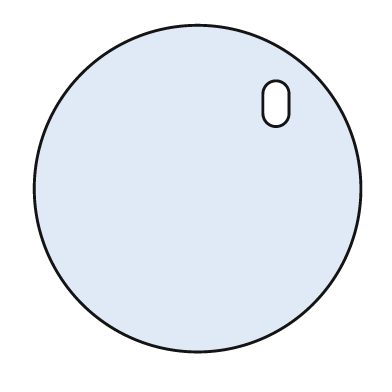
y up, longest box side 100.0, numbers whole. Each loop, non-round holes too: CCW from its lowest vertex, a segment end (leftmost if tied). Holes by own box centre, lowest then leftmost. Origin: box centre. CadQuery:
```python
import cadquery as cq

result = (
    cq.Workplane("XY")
    .moveTo(0.0, 0.0)
    .circle(50.0)
    .moveTo(20.0, 23.0)
    .threePointArc((24.0, 19.0), (28.0, 23.0))
    .lineTo(28.0, 29.0)
    .threePointArc((24.0, 33.0), (20.0, 29.0))
    .close()
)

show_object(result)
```